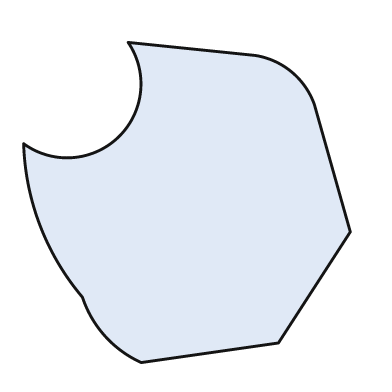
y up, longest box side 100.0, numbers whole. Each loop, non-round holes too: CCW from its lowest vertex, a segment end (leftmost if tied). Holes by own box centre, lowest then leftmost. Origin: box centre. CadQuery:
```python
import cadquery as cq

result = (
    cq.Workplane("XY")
    .moveTo(-14.0, -49.0)
    .lineTo(28.0, -43.0)
    .lineTo(50.0, -9.0)
    .lineTo(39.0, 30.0)
    .threePointArc((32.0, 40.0), (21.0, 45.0))
    .lineTo(-18.0, 49.0)
    .threePointArc((-21.0, 20.0), (-50.0, 18.0))
    .threePointArc((-45.0, -7.0), (-32.0, -29.0))
    .threePointArc((-25.0, -41.0), (-14.0, -49.0))
    .close()
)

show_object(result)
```